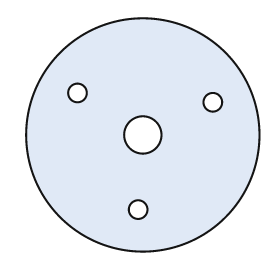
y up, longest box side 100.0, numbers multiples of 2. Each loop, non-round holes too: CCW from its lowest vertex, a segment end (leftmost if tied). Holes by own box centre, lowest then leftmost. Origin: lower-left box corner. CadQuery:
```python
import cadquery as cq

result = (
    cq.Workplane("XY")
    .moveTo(50.0, 50.0)
    .circle(50.0)
    .moveTo(48.0, 18.0)
    .circle(4.0)
    .moveTo(50.0, 50.0)
    .circle(8.0)
    .moveTo(80.0, 64.0)
    .circle(4.0)
    .moveTo(22.0, 68.0)
    .circle(4.0)
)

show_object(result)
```